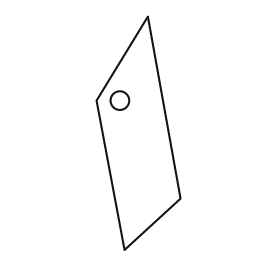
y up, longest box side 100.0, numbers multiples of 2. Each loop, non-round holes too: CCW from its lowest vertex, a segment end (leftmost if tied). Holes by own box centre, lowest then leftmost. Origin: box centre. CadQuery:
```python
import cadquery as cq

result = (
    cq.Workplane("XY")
    .moveTo(-6.0, -50.0)
    .lineTo(18.0, -28.0)
    .lineTo(4.0, 50.0)
    .lineTo(-18.0, 14.0)
    .close()
    .moveTo(-8.0, 14.0)
    .circle(4.0)
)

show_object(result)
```